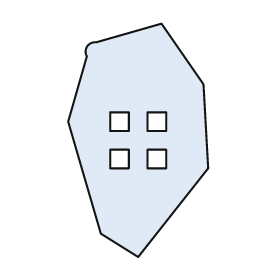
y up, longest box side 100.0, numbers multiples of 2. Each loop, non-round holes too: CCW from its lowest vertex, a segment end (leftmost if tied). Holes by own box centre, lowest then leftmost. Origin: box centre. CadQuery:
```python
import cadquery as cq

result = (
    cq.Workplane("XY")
    .moveTo(0.0, -50.0)
    .lineTo(30.0, -12.0)
    .lineTo(28.0, 24.0)
    .lineTo(10.0, 50.0)
    .lineTo(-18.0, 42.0)
    .threePointArc((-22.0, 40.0), (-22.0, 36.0))
    .lineTo(-30.0, 8.0)
    .lineTo(-16.0, -40.0)
    .close()
    .moveTo(-12.0, -12.0)
    .lineTo(-4.0, -12.0)
    .lineTo(-4.0, -4.0)
    .lineTo(-12.0, -4.0)
    .close()
    .moveTo(4.0, -12.0)
    .lineTo(12.0, -12.0)
    .lineTo(12.0, -4.0)
    .lineTo(4.0, -4.0)
    .close()
    .moveTo(-12.0, 4.0)
    .lineTo(-4.0, 4.0)
    .lineTo(-4.0, 12.0)
    .lineTo(-12.0, 12.0)
    .close()
    .moveTo(4.0, 4.0)
    .lineTo(12.0, 4.0)
    .lineTo(12.0, 12.0)
    .lineTo(4.0, 12.0)
    .close()
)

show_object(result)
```